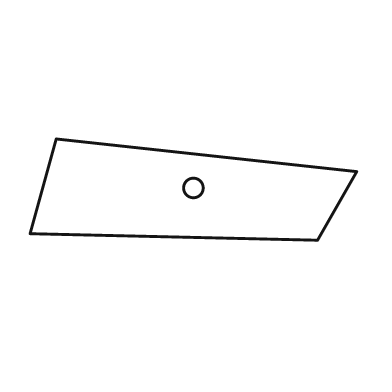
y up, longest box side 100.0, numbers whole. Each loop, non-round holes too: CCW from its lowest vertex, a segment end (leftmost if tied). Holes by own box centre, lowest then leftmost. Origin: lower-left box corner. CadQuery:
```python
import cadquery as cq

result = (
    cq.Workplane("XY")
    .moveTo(88.0, 0.0)
    .lineTo(100.0, 21.0)
    .lineTo(8.0, 31.0)
    .lineTo(0.0, 2.0)
    .close()
    .moveTo(50.0, 16.0)
    .circle(3.0)
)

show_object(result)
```